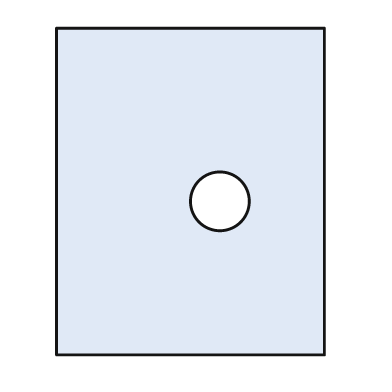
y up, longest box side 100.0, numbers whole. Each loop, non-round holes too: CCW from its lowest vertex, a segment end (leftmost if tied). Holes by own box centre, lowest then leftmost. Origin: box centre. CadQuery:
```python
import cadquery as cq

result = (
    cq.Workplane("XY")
    .moveTo(-41.0, -50.0)
    .lineTo(41.0, -50.0)
    .lineTo(41.0, 50.0)
    .lineTo(-41.0, 50.0)
    .close()
    .moveTo(9.0, -3.0)
    .circle(9.0)
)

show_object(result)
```